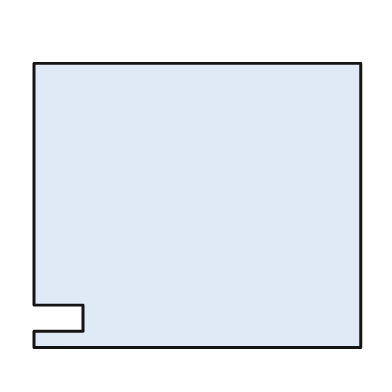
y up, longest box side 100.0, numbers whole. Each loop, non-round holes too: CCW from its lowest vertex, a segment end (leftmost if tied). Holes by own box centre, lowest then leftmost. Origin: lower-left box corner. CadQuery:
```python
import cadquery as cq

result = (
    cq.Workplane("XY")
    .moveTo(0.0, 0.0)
    .lineTo(100.0, 0.0)
    .lineTo(100.0, 87.0)
    .lineTo(0.0, 87.0)
    .lineTo(0.0, 13.0)
    .lineTo(15.0, 13.0)
    .lineTo(15.0, 5.0)
    .lineTo(0.0, 5.0)
    .close()
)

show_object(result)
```